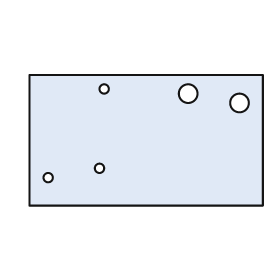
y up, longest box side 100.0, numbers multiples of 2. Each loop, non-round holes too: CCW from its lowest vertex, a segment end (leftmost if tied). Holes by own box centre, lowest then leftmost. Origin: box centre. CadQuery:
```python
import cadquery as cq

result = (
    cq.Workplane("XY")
    .moveTo(-50.0, -28.0)
    .lineTo(50.0, -28.0)
    .lineTo(50.0, 28.0)
    .lineTo(-50.0, 28.0)
    .close()
    .moveTo(-42.0, -16.0)
    .circle(2.0)
    .moveTo(-20.0, -12.0)
    .circle(2.0)
    .moveTo(40.0, 16.0)
    .circle(4.0)
    .moveTo(18.0, 20.0)
    .circle(4.0)
    .moveTo(-18.0, 22.0)
    .circle(2.0)
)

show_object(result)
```